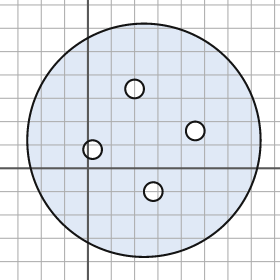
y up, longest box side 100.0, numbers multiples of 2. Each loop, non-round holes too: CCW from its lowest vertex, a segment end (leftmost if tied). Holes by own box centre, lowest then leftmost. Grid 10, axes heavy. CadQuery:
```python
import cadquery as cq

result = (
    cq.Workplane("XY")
    .moveTo(24.0, 12.0)
    .circle(50.0)
    .moveTo(28.0, -10.0)
    .circle(4.0)
    .moveTo(2.0, 8.0)
    .circle(4.0)
    .moveTo(46.0, 16.0)
    .circle(4.0)
    .moveTo(20.0, 34.0)
    .circle(4.0)
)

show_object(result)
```